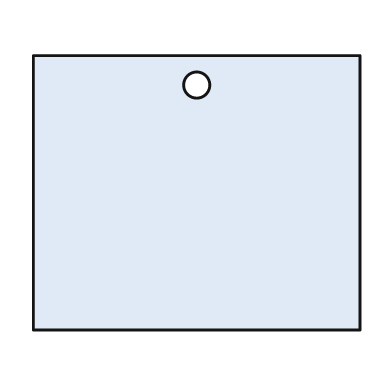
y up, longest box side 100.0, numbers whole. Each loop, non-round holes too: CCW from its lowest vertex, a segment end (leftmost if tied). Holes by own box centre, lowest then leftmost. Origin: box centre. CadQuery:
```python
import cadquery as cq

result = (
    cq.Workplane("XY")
    .moveTo(-50.0, -42.0)
    .lineTo(50.0, -42.0)
    .lineTo(50.0, 42.0)
    .lineTo(-50.0, 42.0)
    .close()
    .moveTo(0.0, 33.0)
    .circle(4.0)
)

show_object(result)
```